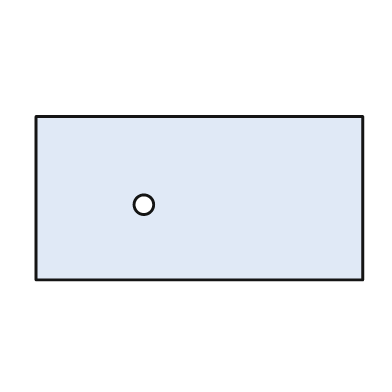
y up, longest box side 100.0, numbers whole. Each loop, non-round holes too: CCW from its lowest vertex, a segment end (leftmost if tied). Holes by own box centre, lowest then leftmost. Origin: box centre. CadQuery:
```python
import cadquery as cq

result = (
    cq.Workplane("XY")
    .moveTo(-50.0, -25.0)
    .lineTo(50.0, -25.0)
    .lineTo(50.0, 25.0)
    .lineTo(-50.0, 25.0)
    .close()
    .moveTo(-17.0, -2.0)
    .circle(3.0)
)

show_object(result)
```